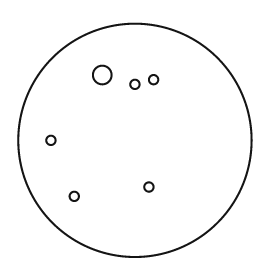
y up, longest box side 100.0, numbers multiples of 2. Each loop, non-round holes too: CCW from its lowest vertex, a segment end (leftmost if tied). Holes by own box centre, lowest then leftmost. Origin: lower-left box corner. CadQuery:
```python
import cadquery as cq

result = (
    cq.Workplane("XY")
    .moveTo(50.0, 50.0)
    .circle(50.0)
    .moveTo(24.0, 26.0)
    .circle(2.0)
    .moveTo(56.0, 30.0)
    .circle(2.0)
    .moveTo(14.0, 50.0)
    .circle(2.0)
    .moveTo(50.0, 74.0)
    .circle(2.0)
    .moveTo(58.0, 76.0)
    .circle(2.0)
    .moveTo(36.0, 78.0)
    .circle(4.0)
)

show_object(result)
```